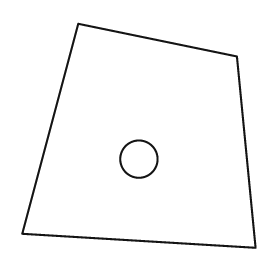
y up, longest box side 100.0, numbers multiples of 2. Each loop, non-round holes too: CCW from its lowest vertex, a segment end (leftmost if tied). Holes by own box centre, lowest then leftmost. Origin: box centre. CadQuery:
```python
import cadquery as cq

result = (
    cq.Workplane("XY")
    .moveTo(50.0, -48.0)
    .lineTo(42.0, 34.0)
    .lineTo(-26.0, 48.0)
    .lineTo(-50.0, -42.0)
    .close()
    .moveTo(0.0, -10.0)
    .circle(8.0)
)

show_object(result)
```